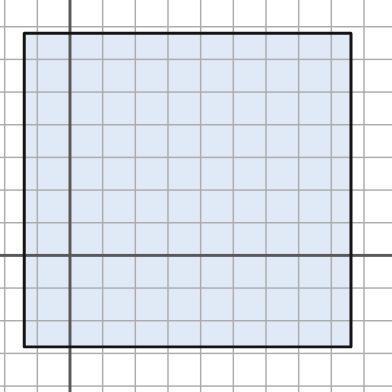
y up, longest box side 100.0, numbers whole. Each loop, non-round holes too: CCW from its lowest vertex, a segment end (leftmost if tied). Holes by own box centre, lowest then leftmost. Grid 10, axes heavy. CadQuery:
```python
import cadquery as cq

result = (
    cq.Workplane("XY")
    .moveTo(-14.0, -28.0)
    .lineTo(86.0, -28.0)
    .lineTo(86.0, 68.0)
    .lineTo(-14.0, 68.0)
    .close()
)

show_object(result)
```